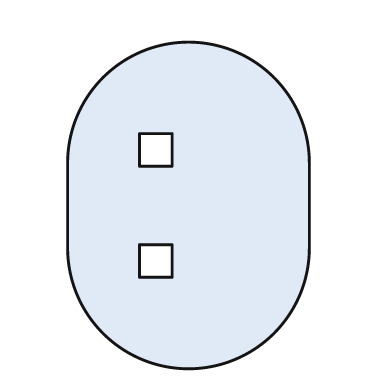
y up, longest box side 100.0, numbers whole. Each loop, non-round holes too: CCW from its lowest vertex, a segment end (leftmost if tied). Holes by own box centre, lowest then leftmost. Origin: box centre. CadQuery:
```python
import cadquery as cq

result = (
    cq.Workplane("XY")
    .moveTo(-37.0, -13.0)
    .threePointArc((0.0, -50.0), (37.0, -13.0))
    .lineTo(37.0, 13.0)
    .threePointArc((0.0, 50.0), (-37.0, 13.0))
    .close()
    .moveTo(-15.0, -22.0)
    .lineTo(-5.0, -22.0)
    .lineTo(-5.0, -12.0)
    .lineTo(-15.0, -12.0)
    .close()
    .moveTo(-15.0, 12.0)
    .lineTo(-5.0, 12.0)
    .lineTo(-5.0, 22.0)
    .lineTo(-15.0, 22.0)
    .close()
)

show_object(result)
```